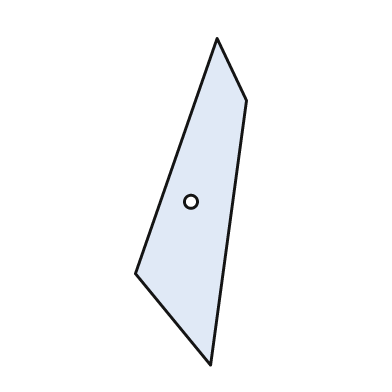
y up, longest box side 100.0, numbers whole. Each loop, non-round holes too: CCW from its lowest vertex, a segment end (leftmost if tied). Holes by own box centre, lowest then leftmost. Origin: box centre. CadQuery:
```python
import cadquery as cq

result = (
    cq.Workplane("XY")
    .moveTo(6.0, -50.0)
    .lineTo(17.0, 31.0)
    .lineTo(8.0, 50.0)
    .lineTo(-17.0, -22.0)
    .close()
    .moveTo(0.0, 0.0)
    .circle(2.0)
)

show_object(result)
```